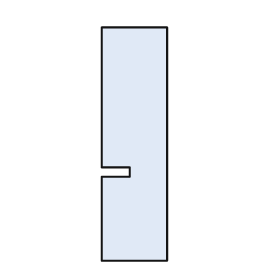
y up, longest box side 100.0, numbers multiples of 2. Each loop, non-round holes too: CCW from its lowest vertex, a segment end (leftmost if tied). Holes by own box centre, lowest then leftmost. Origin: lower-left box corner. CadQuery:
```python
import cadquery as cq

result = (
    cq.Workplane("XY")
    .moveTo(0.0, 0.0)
    .lineTo(28.0, 0.0)
    .lineTo(28.0, 100.0)
    .lineTo(0.0, 100.0)
    .lineTo(0.0, 40.0)
    .lineTo(12.0, 40.0)
    .lineTo(12.0, 36.0)
    .lineTo(0.0, 36.0)
    .close()
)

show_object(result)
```